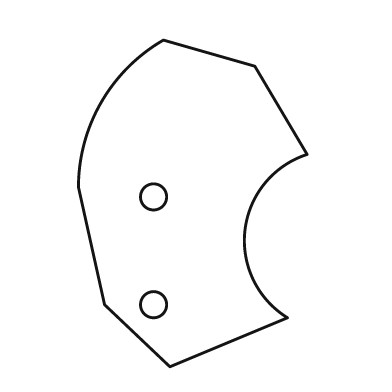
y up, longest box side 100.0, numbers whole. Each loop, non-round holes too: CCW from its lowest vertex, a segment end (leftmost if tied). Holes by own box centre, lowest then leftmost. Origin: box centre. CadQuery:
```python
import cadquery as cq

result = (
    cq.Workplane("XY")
    .moveTo(-7.0, -50.0)
    .lineTo(29.0, -35.0)
    .threePointArc((16.0, -8.0), (35.0, 15.0))
    .lineTo(19.0, 42.0)
    .lineTo(-9.0, 50.0)
    .threePointArc((-28.0, 31.0), (-35.0, 5.0))
    .lineTo(-27.0, -31.0)
    .close()
    .moveTo(-12.0, -31.0)
    .circle(4.0)
    .moveTo(-12.0, 2.0)
    .circle(4.0)
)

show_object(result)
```